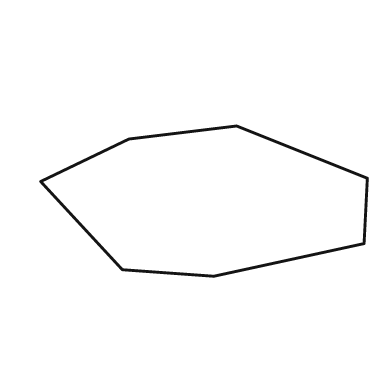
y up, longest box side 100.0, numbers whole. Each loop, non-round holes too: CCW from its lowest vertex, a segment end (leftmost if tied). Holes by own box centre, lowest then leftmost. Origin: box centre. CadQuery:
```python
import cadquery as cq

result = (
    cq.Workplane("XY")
    .moveTo(3.0, -23.0)
    .lineTo(49.0, -13.0)
    .lineTo(50.0, 7.0)
    .lineTo(10.0, 23.0)
    .lineTo(-23.0, 19.0)
    .lineTo(-50.0, 6.0)
    .lineTo(-25.0, -21.0)
    .close()
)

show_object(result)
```